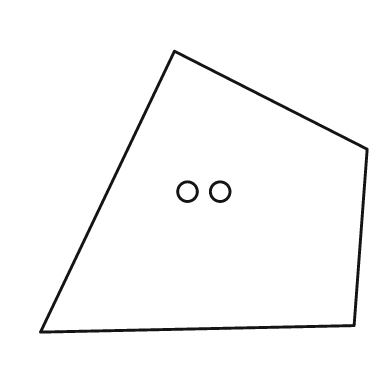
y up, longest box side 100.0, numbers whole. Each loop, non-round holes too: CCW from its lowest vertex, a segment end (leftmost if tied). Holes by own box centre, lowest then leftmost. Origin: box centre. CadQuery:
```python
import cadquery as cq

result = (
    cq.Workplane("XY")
    .moveTo(-50.0, -43.0)
    .lineTo(46.0, -41.0)
    .lineTo(50.0, 13.0)
    .lineTo(-9.0, 43.0)
    .close()
    .moveTo(-5.0, 0.0)
    .circle(3.0)
    .moveTo(5.0, 0.0)
    .circle(3.0)
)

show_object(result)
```